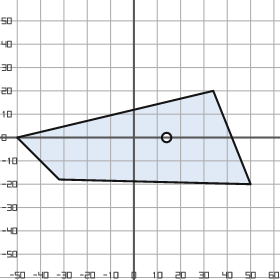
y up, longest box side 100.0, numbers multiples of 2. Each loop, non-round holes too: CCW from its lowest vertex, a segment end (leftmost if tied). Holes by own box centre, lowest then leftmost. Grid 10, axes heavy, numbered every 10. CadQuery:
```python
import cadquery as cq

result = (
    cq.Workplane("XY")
    .moveTo(50.0, -20.0)
    .lineTo(34.0, 20.0)
    .lineTo(-50.0, 0.0)
    .lineTo(-32.0, -18.0)
    .close()
    .moveTo(14.0, 0.0)
    .circle(2.0)
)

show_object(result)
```